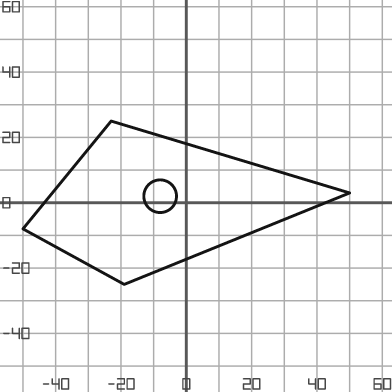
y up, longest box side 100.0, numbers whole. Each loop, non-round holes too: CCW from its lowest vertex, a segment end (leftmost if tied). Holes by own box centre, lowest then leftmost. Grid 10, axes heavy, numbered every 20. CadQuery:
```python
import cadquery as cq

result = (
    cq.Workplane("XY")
    .moveTo(-19.0, -25.0)
    .lineTo(50.0, 3.0)
    .lineTo(-23.0, 25.0)
    .lineTo(-50.0, -8.0)
    .close()
    .moveTo(-8.0, 2.0)
    .circle(5.0)
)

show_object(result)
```